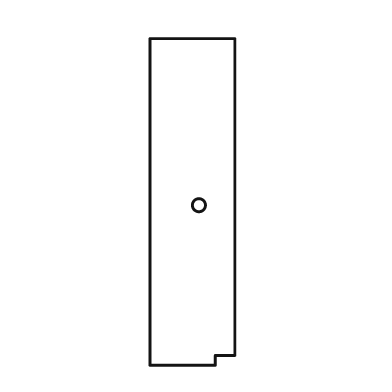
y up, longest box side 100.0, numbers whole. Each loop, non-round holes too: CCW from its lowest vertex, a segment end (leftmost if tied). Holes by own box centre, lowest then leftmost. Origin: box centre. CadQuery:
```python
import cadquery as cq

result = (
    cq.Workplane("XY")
    .moveTo(-13.0, -50.0)
    .lineTo(7.0, -50.0)
    .lineTo(7.0, -47.0)
    .lineTo(13.0, -47.0)
    .lineTo(13.0, 50.0)
    .lineTo(-13.0, 50.0)
    .close()
    .moveTo(2.0, -1.0)
    .circle(2.0)
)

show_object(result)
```